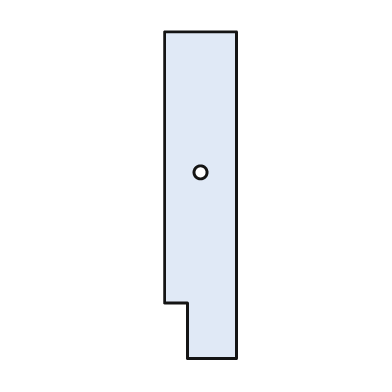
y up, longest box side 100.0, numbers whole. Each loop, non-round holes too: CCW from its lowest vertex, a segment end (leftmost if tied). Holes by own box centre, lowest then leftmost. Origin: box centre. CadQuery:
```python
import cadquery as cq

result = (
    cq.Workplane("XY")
    .moveTo(-4.0, -50.0)
    .lineTo(11.0, -50.0)
    .lineTo(11.0, 50.0)
    .lineTo(-11.0, 50.0)
    .lineTo(-11.0, -33.0)
    .lineTo(-4.0, -33.0)
    .close()
    .moveTo(0.0, 7.0)
    .circle(2.0)
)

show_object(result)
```